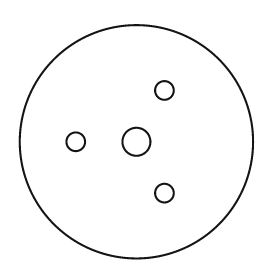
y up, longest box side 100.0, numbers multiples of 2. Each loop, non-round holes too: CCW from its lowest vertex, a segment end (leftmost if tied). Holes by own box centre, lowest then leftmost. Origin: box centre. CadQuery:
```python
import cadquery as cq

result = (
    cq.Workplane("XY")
    .moveTo(0.0, 0.0)
    .circle(50.0)
    .moveTo(12.0, -22.0)
    .circle(4.0)
    .moveTo(-26.0, 0.0)
    .circle(4.0)
    .moveTo(0.0, 0.0)
    .circle(6.0)
    .moveTo(12.0, 22.0)
    .circle(4.0)
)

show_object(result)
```